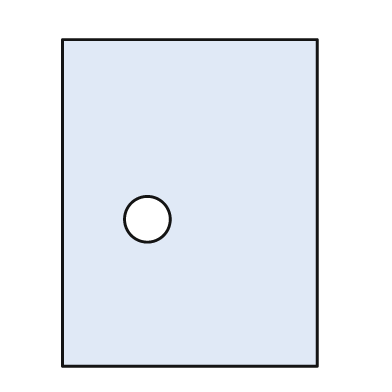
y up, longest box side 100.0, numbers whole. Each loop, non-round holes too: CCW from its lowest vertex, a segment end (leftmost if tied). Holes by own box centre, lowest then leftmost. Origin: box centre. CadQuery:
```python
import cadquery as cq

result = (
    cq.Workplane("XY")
    .moveTo(-39.0, -50.0)
    .lineTo(39.0, -50.0)
    .lineTo(39.0, 50.0)
    .lineTo(-39.0, 50.0)
    .close()
    .moveTo(-13.0, -5.0)
    .circle(7.0)
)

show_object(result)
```